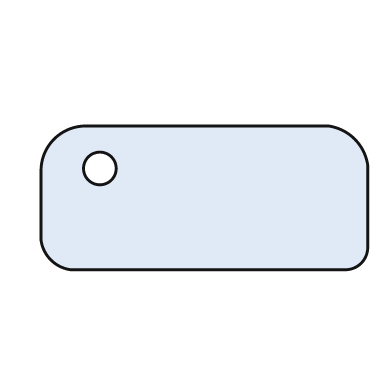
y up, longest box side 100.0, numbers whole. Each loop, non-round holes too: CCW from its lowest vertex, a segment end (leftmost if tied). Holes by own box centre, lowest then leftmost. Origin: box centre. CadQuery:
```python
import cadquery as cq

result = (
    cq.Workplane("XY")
    .moveTo(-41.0, -22.0)
    .lineTo(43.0, -22.0)
    .threePointArc((48.0, -20.0), (50.0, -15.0))
    .lineTo(50.0, 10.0)
    .threePointArc((46.0, 18.0), (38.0, 22.0))
    .lineTo(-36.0, 22.0)
    .threePointArc((-46.0, 18.0), (-50.0, 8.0))
    .lineTo(-50.0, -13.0)
    .threePointArc((-47.0, -19.0), (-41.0, -22.0))
    .close()
    .moveTo(-32.0, 9.0)
    .circle(5.0)
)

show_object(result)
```